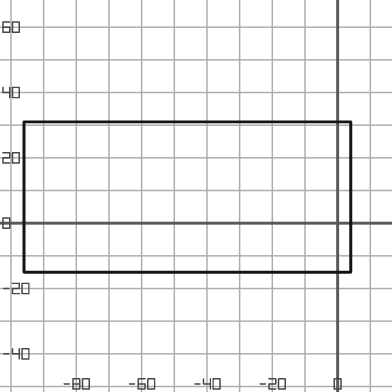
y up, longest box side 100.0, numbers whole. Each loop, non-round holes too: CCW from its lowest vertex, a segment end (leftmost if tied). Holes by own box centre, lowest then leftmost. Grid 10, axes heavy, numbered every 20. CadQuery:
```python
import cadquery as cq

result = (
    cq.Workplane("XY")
    .moveTo(-96.0, -15.0)
    .lineTo(4.0, -15.0)
    .lineTo(4.0, 31.0)
    .lineTo(-96.0, 31.0)
    .close()
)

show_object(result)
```